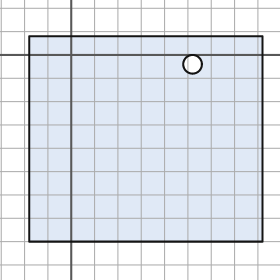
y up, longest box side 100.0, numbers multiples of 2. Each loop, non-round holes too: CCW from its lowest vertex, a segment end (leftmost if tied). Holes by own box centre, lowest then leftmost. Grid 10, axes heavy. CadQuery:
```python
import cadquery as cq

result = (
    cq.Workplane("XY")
    .moveTo(-18.0, -80.0)
    .lineTo(82.0, -80.0)
    .lineTo(82.0, 8.0)
    .lineTo(-18.0, 8.0)
    .close()
    .moveTo(52.0, -4.0)
    .circle(4.0)
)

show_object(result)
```